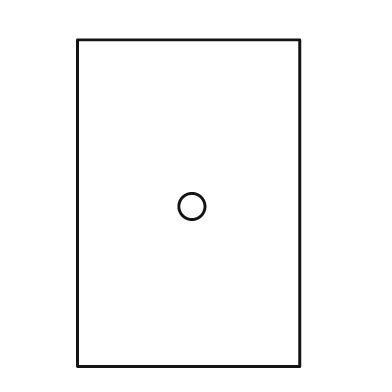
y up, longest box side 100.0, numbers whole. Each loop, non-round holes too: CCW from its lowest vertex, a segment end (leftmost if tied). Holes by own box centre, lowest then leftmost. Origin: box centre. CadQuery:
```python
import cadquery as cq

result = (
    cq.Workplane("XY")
    .moveTo(-34.0, -50.0)
    .lineTo(34.0, -50.0)
    .lineTo(34.0, 50.0)
    .lineTo(-34.0, 50.0)
    .close()
    .moveTo(1.0, -1.0)
    .circle(4.0)
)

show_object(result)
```